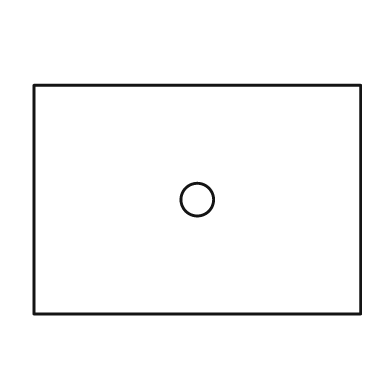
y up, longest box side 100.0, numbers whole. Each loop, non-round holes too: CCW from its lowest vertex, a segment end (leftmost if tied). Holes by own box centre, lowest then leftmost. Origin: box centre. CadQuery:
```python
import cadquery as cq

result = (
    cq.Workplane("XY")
    .moveTo(-50.0, -35.0)
    .lineTo(50.0, -35.0)
    .lineTo(50.0, 35.0)
    .lineTo(-50.0, 35.0)
    .close()
    .moveTo(0.0, 0.0)
    .circle(5.0)
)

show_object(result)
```